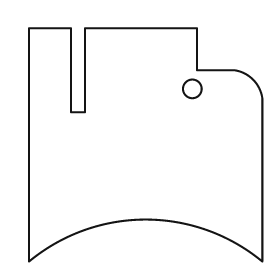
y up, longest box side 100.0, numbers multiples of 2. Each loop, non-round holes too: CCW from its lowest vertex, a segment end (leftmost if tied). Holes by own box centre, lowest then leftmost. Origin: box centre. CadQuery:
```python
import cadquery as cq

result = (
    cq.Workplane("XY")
    .moveTo(-50.0, -50.0)
    .threePointArc((0.0, -32.0), (50.0, -50.0))
    .lineTo(50.0, 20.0)
    .threePointArc((46.0, 28.0), (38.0, 32.0))
    .lineTo(22.0, 32.0)
    .lineTo(22.0, 50.0)
    .lineTo(-26.0, 50.0)
    .lineTo(-26.0, 14.0)
    .lineTo(-32.0, 14.0)
    .lineTo(-32.0, 50.0)
    .lineTo(-50.0, 50.0)
    .close()
    .moveTo(20.0, 24.0)
    .circle(4.0)
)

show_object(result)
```